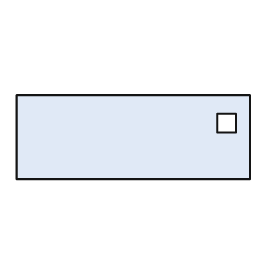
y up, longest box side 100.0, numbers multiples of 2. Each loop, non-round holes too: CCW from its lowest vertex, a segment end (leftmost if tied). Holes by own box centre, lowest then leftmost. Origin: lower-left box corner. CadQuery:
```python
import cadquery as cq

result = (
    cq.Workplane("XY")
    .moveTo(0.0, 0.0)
    .lineTo(100.0, 0.0)
    .lineTo(100.0, 36.0)
    .lineTo(0.0, 36.0)
    .close()
    .moveTo(86.0, 20.0)
    .lineTo(94.0, 20.0)
    .lineTo(94.0, 28.0)
    .lineTo(86.0, 28.0)
    .close()
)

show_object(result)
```